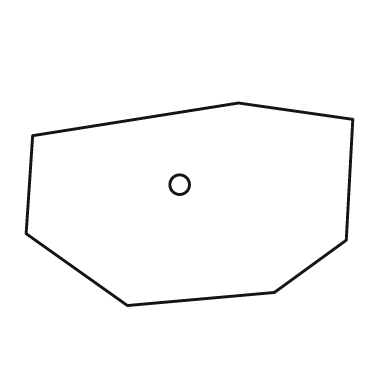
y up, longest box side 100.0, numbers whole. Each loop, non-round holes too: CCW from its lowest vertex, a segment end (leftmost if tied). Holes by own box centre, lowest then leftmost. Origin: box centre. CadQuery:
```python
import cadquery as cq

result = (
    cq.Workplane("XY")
    .moveTo(-19.0, -31.0)
    .lineTo(26.0, -27.0)
    .lineTo(48.0, -11.0)
    .lineTo(50.0, 26.0)
    .lineTo(15.0, 31.0)
    .lineTo(-48.0, 21.0)
    .lineTo(-50.0, -9.0)
    .close()
    .moveTo(-3.0, 6.0)
    .circle(3.0)
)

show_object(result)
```